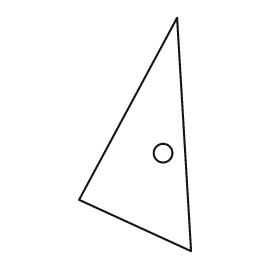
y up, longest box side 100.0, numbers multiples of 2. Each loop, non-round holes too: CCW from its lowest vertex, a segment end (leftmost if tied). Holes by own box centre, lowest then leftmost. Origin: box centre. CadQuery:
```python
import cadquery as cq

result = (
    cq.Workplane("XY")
    .moveTo(24.0, -50.0)
    .lineTo(18.0, 50.0)
    .lineTo(-24.0, -28.0)
    .close()
    .moveTo(12.0, -8.0)
    .circle(4.0)
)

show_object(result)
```